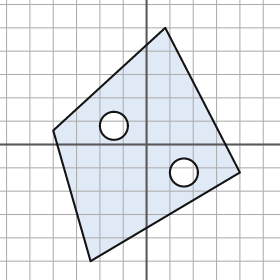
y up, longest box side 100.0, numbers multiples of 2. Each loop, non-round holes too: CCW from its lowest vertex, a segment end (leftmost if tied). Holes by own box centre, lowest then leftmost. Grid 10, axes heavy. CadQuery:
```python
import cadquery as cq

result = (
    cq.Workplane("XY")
    .moveTo(-24.0, -50.0)
    .lineTo(40.0, -12.0)
    .lineTo(8.0, 50.0)
    .lineTo(-40.0, 6.0)
    .close()
    .moveTo(16.0, -12.0)
    .circle(6.0)
    .moveTo(-14.0, 8.0)
    .circle(6.0)
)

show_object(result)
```